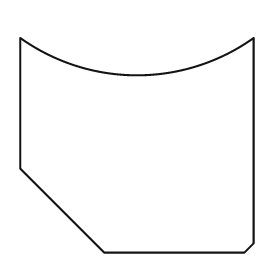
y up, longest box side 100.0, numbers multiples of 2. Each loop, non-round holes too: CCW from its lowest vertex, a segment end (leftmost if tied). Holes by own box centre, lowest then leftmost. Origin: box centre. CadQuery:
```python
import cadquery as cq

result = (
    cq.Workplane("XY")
    .moveTo(-14.0, -46.0)
    .lineTo(46.0, -46.0)
    .lineTo(50.0, -42.0)
    .lineTo(50.0, 46.0)
    .threePointArc((0.0, 30.0), (-50.0, 46.0))
    .lineTo(-50.0, -10.0)
    .close()
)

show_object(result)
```